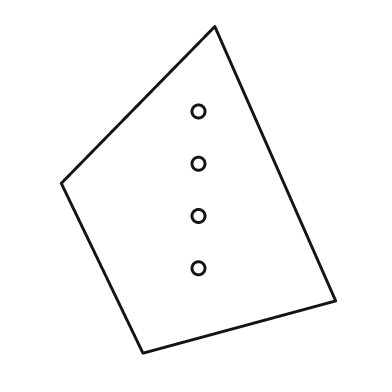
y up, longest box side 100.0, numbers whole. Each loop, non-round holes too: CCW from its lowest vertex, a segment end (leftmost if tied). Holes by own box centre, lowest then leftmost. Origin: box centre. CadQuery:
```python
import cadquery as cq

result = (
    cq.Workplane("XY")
    .moveTo(-17.0, -50.0)
    .lineTo(42.0, -34.0)
    .lineTo(5.0, 50.0)
    .lineTo(-42.0, 2.0)
    .close()
    .moveTo(0.0, -24.0)
    .circle(2.0)
    .moveTo(0.0, -8.0)
    .circle(2.0)
    .moveTo(0.0, 8.0)
    .circle(2.0)
    .moveTo(0.0, 24.0)
    .circle(2.0)
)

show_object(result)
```